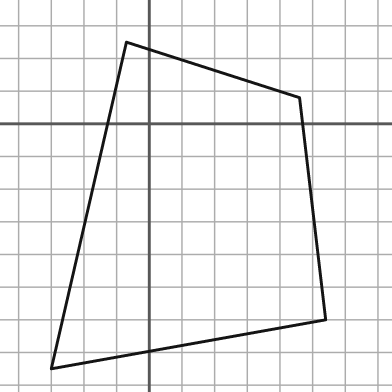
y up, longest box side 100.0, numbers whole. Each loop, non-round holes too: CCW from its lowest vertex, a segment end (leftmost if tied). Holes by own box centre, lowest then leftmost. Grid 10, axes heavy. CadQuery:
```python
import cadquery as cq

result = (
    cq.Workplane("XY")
    .moveTo(-30.0, -75.0)
    .lineTo(54.0, -60.0)
    .lineTo(46.0, 8.0)
    .lineTo(-7.0, 25.0)
    .close()
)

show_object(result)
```